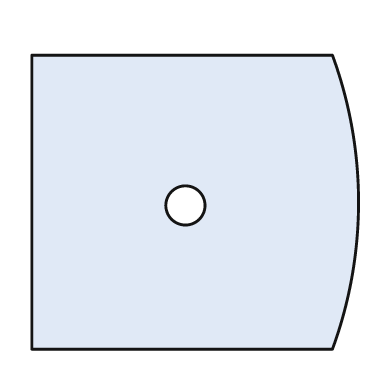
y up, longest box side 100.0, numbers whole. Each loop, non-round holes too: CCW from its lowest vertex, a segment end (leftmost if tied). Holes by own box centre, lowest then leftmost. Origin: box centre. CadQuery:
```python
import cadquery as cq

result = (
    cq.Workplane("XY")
    .moveTo(-50.0, -45.0)
    .lineTo(42.0, -45.0)
    .threePointArc((50.0, 0.0), (42.0, 45.0))
    .lineTo(-50.0, 45.0)
    .close()
    .moveTo(-3.0, -1.0)
    .circle(6.0)
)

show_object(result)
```